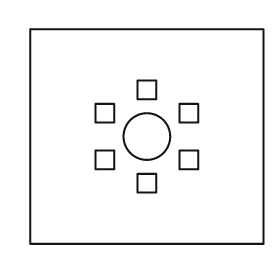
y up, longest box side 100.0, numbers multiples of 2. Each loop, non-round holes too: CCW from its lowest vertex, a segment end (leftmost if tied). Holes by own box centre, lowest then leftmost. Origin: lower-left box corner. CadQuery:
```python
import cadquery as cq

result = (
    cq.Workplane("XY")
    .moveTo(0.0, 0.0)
    .lineTo(100.0, 0.0)
    .lineTo(100.0, 92.0)
    .lineTo(0.0, 92.0)
    .close()
    .moveTo(46.0, 22.0)
    .lineTo(54.0, 22.0)
    .lineTo(54.0, 30.0)
    .lineTo(46.0, 30.0)
    .close()
    .moveTo(28.0, 32.0)
    .lineTo(36.0, 32.0)
    .lineTo(36.0, 40.0)
    .lineTo(28.0, 40.0)
    .close()
    .moveTo(64.0, 32.0)
    .lineTo(72.0, 32.0)
    .lineTo(72.0, 40.0)
    .lineTo(64.0, 40.0)
    .close()
    .moveTo(50.0, 46.0)
    .circle(10.0)
    .moveTo(28.0, 52.0)
    .lineTo(36.0, 52.0)
    .lineTo(36.0, 60.0)
    .lineTo(28.0, 60.0)
    .close()
    .moveTo(64.0, 52.0)
    .lineTo(72.0, 52.0)
    .lineTo(72.0, 60.0)
    .lineTo(64.0, 60.0)
    .close()
    .moveTo(46.0, 62.0)
    .lineTo(54.0, 62.0)
    .lineTo(54.0, 70.0)
    .lineTo(46.0, 70.0)
    .close()
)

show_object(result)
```